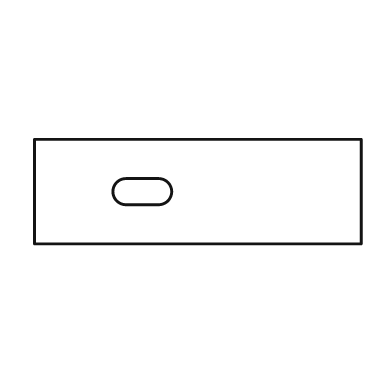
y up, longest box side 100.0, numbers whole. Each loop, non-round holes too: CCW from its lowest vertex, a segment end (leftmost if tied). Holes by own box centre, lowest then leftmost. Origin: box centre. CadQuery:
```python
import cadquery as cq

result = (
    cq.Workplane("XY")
    .moveTo(-50.0, -16.0)
    .lineTo(50.0, -16.0)
    .lineTo(50.0, 16.0)
    .lineTo(-50.0, 16.0)
    .close()
    .moveTo(-22.0, -4.0)
    .lineTo(-12.0, -4.0)
    .threePointArc((-8.0, 0.0), (-12.0, 4.0))
    .lineTo(-22.0, 4.0)
    .threePointArc((-26.0, 0.0), (-22.0, -4.0))
    .close()
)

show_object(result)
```